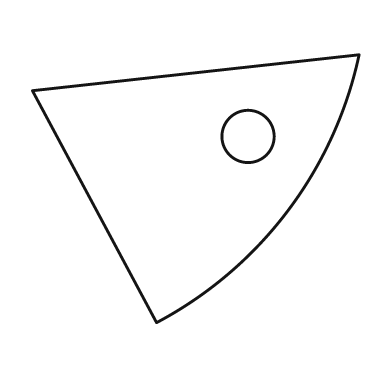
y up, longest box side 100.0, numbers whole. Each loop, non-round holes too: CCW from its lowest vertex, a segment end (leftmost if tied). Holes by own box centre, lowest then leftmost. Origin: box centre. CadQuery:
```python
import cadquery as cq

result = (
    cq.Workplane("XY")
    .moveTo(-12.0, -41.0)
    .threePointArc((28.0, -7.0), (50.0, 41.0))
    .lineTo(-50.0, 30.0)
    .close()
    .moveTo(16.0, 16.0)
    .circle(8.0)
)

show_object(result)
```